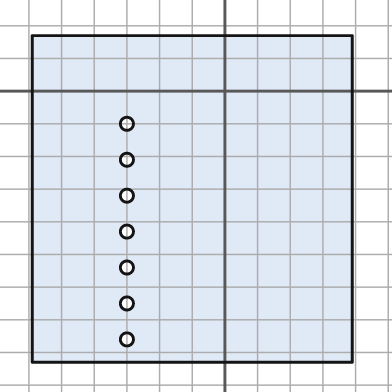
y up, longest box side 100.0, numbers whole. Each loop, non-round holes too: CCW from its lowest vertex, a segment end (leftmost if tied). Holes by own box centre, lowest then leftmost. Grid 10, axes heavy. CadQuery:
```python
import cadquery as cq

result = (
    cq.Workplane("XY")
    .moveTo(-59.0, -83.0)
    .lineTo(39.0, -83.0)
    .lineTo(39.0, 17.0)
    .lineTo(-59.0, 17.0)
    .close()
    .moveTo(-30.0, -76.0)
    .circle(2.0)
    .moveTo(-30.0, -65.0)
    .circle(2.0)
    .moveTo(-30.0, -54.0)
    .circle(2.0)
    .moveTo(-30.0, -43.0)
    .circle(2.0)
    .moveTo(-30.0, -32.0)
    .circle(2.0)
    .moveTo(-30.0, -21.0)
    .circle(2.0)
    .moveTo(-30.0, -10.0)
    .circle(2.0)
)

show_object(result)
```